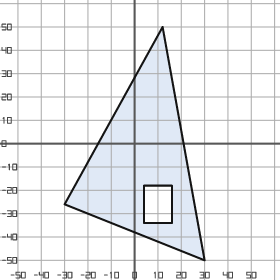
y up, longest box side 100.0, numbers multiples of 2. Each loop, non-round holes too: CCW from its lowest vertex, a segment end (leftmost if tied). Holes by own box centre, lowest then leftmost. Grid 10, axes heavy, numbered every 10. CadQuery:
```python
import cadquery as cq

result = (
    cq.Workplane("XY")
    .moveTo(30.0, -50.0)
    .lineTo(12.0, 50.0)
    .lineTo(-30.0, -26.0)
    .close()
    .moveTo(4.0, -34.0)
    .lineTo(16.0, -34.0)
    .lineTo(16.0, -18.0)
    .lineTo(4.0, -18.0)
    .close()
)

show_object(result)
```